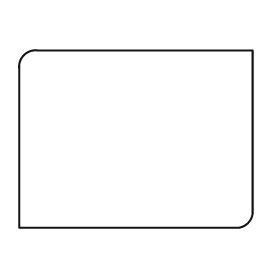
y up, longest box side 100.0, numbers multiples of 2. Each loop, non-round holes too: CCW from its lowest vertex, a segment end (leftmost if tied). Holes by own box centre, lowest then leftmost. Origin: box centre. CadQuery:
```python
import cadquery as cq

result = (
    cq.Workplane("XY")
    .moveTo(-50.0, -38.0)
    .lineTo(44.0, -38.0)
    .threePointArc((48.0, -36.0), (50.0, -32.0))
    .lineTo(50.0, 38.0)
    .lineTo(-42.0, 38.0)
    .threePointArc((-48.0, 36.0), (-50.0, 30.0))
    .close()
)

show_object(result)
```